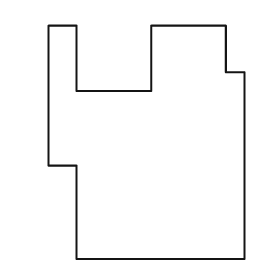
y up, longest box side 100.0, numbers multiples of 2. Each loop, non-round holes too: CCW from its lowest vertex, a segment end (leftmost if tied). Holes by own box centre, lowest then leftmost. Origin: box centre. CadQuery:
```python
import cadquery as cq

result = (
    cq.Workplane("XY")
    .moveTo(-30.0, -50.0)
    .lineTo(42.0, -50.0)
    .lineTo(42.0, 30.0)
    .lineTo(34.0, 30.0)
    .lineTo(34.0, 50.0)
    .lineTo(2.0, 50.0)
    .lineTo(2.0, 22.0)
    .lineTo(-30.0, 22.0)
    .lineTo(-30.0, 50.0)
    .lineTo(-42.0, 50.0)
    .lineTo(-42.0, -10.0)
    .lineTo(-30.0, -10.0)
    .close()
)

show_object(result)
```